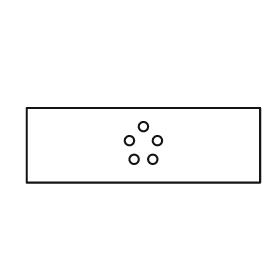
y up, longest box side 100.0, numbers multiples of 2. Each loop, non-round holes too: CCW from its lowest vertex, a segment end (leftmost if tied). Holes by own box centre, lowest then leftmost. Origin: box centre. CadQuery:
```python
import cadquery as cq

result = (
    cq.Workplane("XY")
    .moveTo(-50.0, -16.0)
    .lineTo(50.0, -16.0)
    .lineTo(50.0, 16.0)
    .lineTo(-50.0, 16.0)
    .close()
    .moveTo(-4.0, -6.0)
    .circle(2.0)
    .moveTo(4.0, -6.0)
    .circle(2.0)
    .moveTo(-6.0, 2.0)
    .circle(2.0)
    .moveTo(6.0, 2.0)
    .circle(2.0)
    .moveTo(0.0, 8.0)
    .circle(2.0)
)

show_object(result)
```